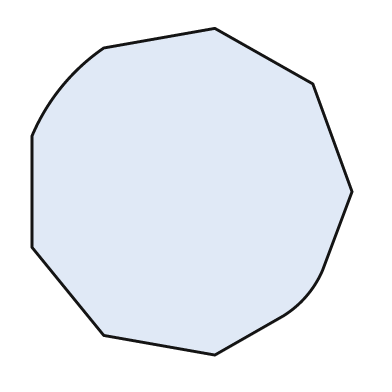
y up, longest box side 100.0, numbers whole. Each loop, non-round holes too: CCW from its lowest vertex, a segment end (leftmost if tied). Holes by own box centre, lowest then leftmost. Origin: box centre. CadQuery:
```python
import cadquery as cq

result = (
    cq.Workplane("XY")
    .moveTo(7.0, -50.0)
    .lineTo(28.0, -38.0)
    .threePointArc((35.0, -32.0), (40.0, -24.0))
    .lineTo(49.0, 0.0)
    .lineTo(37.0, 33.0)
    .lineTo(7.0, 50.0)
    .lineTo(-27.0, 44.0)
    .threePointArc((-40.0, 32.0), (-49.0, 17.0))
    .lineTo(-49.0, -17.0)
    .lineTo(-27.0, -44.0)
    .close()
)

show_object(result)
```